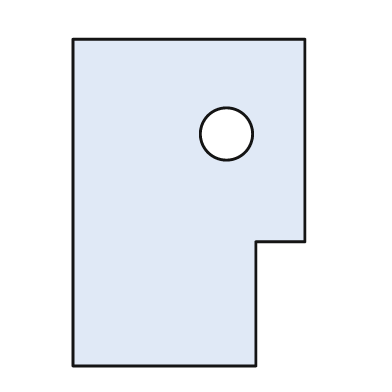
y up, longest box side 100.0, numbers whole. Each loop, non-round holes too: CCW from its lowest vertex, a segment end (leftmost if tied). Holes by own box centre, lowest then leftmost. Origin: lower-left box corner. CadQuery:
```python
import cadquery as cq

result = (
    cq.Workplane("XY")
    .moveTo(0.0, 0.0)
    .lineTo(56.0, 0.0)
    .lineTo(56.0, 38.0)
    .lineTo(71.0, 38.0)
    .lineTo(71.0, 100.0)
    .lineTo(0.0, 100.0)
    .close()
    .moveTo(47.0, 71.0)
    .circle(8.0)
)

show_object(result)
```